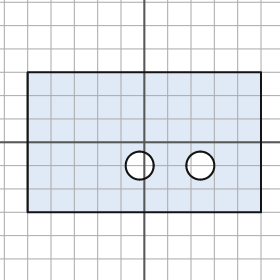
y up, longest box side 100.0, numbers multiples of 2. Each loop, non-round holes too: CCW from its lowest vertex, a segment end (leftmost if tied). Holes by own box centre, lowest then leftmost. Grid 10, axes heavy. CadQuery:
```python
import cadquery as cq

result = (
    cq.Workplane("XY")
    .moveTo(-50.0, -30.0)
    .lineTo(50.0, -30.0)
    .lineTo(50.0, 30.0)
    .lineTo(-50.0, 30.0)
    .close()
    .moveTo(-2.0, -10.0)
    .circle(6.0)
    .moveTo(24.0, -10.0)
    .circle(6.0)
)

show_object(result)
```